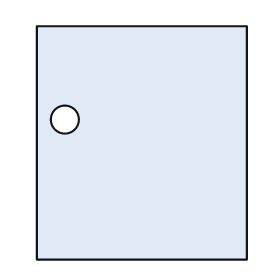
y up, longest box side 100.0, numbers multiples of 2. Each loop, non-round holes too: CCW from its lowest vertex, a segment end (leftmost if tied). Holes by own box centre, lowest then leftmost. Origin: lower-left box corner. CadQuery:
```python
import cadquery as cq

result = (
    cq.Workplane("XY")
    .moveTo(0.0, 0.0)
    .lineTo(90.0, 0.0)
    .lineTo(90.0, 100.0)
    .lineTo(0.0, 100.0)
    .close()
    .moveTo(12.0, 60.0)
    .circle(6.0)
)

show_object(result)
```